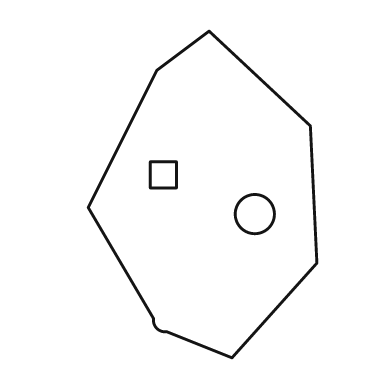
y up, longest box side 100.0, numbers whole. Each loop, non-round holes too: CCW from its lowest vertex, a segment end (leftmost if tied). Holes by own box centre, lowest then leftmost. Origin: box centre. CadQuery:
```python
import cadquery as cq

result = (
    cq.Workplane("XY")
    .moveTo(9.0, -50.0)
    .lineTo(35.0, -21.0)
    .lineTo(33.0, 21.0)
    .lineTo(2.0, 50.0)
    .lineTo(-14.0, 38.0)
    .lineTo(-35.0, -4.0)
    .lineTo(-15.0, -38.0)
    .threePointArc((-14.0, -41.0), (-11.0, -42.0))
    .close()
    .moveTo(16.0, -6.0)
    .circle(6.0)
    .moveTo(-16.0, 2.0)
    .lineTo(-8.0, 2.0)
    .lineTo(-8.0, 10.0)
    .lineTo(-16.0, 10.0)
    .close()
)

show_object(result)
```